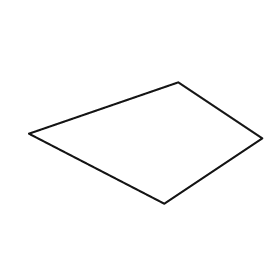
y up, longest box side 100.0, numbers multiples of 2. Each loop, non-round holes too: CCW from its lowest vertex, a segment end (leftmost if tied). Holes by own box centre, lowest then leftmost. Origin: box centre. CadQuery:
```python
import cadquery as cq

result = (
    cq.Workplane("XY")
    .moveTo(8.0, -26.0)
    .lineTo(50.0, 2.0)
    .lineTo(14.0, 26.0)
    .lineTo(-50.0, 4.0)
    .close()
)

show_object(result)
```